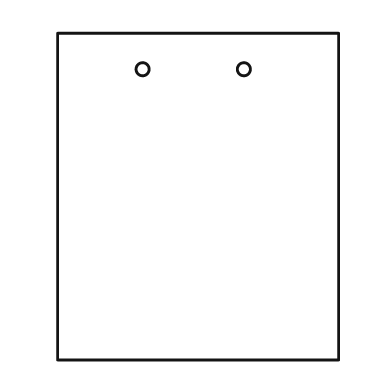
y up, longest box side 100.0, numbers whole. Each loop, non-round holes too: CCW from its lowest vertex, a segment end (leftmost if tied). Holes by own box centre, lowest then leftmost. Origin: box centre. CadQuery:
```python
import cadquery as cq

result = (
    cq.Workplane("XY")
    .moveTo(-43.0, -50.0)
    .lineTo(43.0, -50.0)
    .lineTo(43.0, 50.0)
    .lineTo(-43.0, 50.0)
    .close()
    .moveTo(-17.0, 39.0)
    .circle(2.0)
    .moveTo(14.0, 39.0)
    .circle(2.0)
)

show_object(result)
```